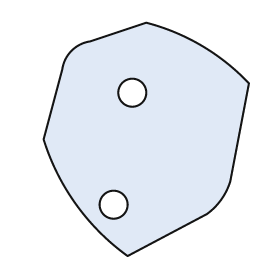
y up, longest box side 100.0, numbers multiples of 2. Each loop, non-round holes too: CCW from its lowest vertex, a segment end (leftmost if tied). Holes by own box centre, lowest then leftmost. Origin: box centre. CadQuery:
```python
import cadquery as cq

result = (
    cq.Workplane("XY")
    .moveTo(-8.0, -50.0)
    .lineTo(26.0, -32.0)
    .threePointArc((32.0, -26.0), (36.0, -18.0))
    .lineTo(44.0, 24.0)
    .threePointArc((24.0, 40.0), (0.0, 50.0))
    .lineTo(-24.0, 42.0)
    .threePointArc((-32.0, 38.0), (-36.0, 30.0))
    .lineTo(-44.0, 0.0)
    .threePointArc((-30.0, -28.0), (-8.0, -50.0))
    .close()
    .moveTo(-14.0, -28.0)
    .circle(6.0)
    .moveTo(-6.0, 20.0)
    .circle(6.0)
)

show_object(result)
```